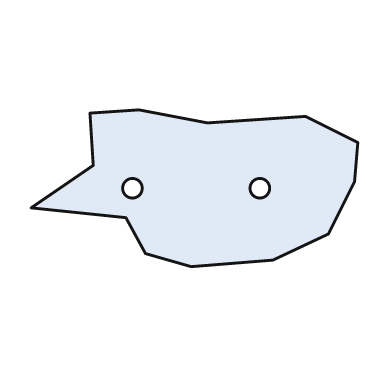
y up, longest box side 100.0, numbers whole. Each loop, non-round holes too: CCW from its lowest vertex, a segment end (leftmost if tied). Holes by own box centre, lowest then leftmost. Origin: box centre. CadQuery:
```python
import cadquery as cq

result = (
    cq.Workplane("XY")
    .moveTo(-1.0, -24.0)
    .lineTo(24.0, -22.0)
    .lineTo(41.0, -14.0)
    .lineTo(49.0, 2.0)
    .lineTo(50.0, 14.0)
    .lineTo(34.0, 22.0)
    .lineTo(4.0, 20.0)
    .lineTo(-17.0, 24.0)
    .lineTo(-32.0, 23.0)
    .lineTo(-31.0, 7.0)
    .lineTo(-50.0, -6.0)
    .lineTo(-21.0, -9.0)
    .lineTo(-15.0, -20.0)
    .close()
    .moveTo(-19.0, 0.0)
    .circle(3.0)
    .moveTo(20.0, 0.0)
    .circle(3.0)
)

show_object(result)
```